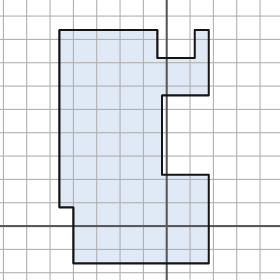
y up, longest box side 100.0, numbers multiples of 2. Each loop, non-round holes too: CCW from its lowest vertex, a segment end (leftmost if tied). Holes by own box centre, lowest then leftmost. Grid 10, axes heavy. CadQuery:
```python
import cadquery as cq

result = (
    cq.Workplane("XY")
    .moveTo(-40.0, -16.0)
    .lineTo(18.0, -16.0)
    .lineTo(18.0, 22.0)
    .lineTo(-2.0, 22.0)
    .lineTo(-2.0, 56.0)
    .lineTo(18.0, 56.0)
    .lineTo(18.0, 84.0)
    .lineTo(12.0, 84.0)
    .lineTo(12.0, 72.0)
    .lineTo(-4.0, 72.0)
    .lineTo(-4.0, 84.0)
    .lineTo(-46.0, 84.0)
    .lineTo(-46.0, 8.0)
    .lineTo(-40.0, 8.0)
    .close()
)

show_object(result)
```